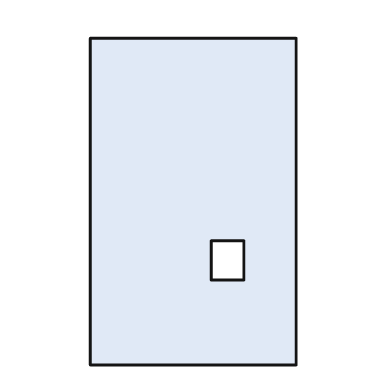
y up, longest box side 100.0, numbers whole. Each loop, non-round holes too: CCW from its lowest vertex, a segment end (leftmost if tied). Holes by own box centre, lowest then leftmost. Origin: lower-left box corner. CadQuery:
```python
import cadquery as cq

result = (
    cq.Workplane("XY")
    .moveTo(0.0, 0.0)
    .lineTo(63.0, 0.0)
    .lineTo(63.0, 100.0)
    .lineTo(0.0, 100.0)
    .close()
    .moveTo(37.0, 26.0)
    .lineTo(47.0, 26.0)
    .lineTo(47.0, 38.0)
    .lineTo(37.0, 38.0)
    .close()
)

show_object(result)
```